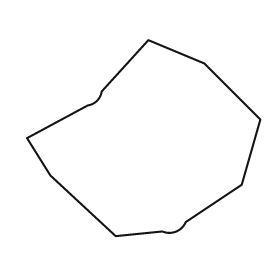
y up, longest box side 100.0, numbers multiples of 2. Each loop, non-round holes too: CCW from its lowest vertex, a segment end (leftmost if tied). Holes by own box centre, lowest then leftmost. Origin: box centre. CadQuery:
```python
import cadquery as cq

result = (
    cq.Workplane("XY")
    .moveTo(-12.0, -42.0)
    .lineTo(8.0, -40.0)
    .threePointArc((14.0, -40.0), (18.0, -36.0))
    .lineTo(42.0, -20.0)
    .lineTo(50.0, 8.0)
    .lineTo(26.0, 32.0)
    .lineTo(2.0, 42.0)
    .lineTo(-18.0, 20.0)
    .threePointArc((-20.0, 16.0), (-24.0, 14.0))
    .lineTo(-50.0, 0.0)
    .lineTo(-40.0, -16.0)
    .close()
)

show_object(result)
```